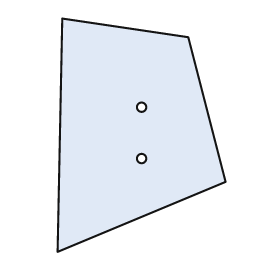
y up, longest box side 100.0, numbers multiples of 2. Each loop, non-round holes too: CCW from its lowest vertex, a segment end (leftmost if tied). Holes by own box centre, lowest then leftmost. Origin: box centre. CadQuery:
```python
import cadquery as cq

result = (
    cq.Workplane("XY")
    .moveTo(-36.0, -50.0)
    .lineTo(36.0, -20.0)
    .lineTo(20.0, 42.0)
    .lineTo(-34.0, 50.0)
    .close()
    .moveTo(0.0, -10.0)
    .circle(2.0)
    .moveTo(0.0, 12.0)
    .circle(2.0)
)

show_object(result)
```